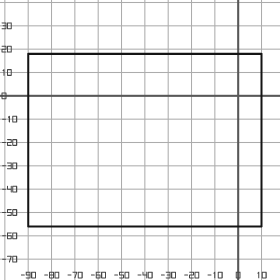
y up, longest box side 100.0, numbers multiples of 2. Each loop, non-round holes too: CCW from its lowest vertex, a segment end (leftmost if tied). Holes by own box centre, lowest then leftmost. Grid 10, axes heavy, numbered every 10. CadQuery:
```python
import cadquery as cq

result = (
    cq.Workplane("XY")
    .moveTo(-90.0, -56.0)
    .lineTo(10.0, -56.0)
    .lineTo(10.0, 18.0)
    .lineTo(-90.0, 18.0)
    .close()
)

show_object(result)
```